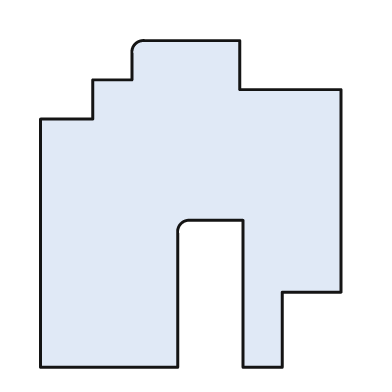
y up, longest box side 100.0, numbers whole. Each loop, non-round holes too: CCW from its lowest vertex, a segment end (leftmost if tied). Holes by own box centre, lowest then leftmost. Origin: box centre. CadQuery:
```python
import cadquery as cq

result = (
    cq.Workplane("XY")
    .moveTo(-46.0, -50.0)
    .lineTo(-4.0, -50.0)
    .lineTo(-4.0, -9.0)
    .threePointArc((-3.0, -6.0), (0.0, -5.0))
    .lineTo(16.0, -5.0)
    .lineTo(16.0, -50.0)
    .lineTo(28.0, -50.0)
    .lineTo(28.0, -27.0)
    .lineTo(46.0, -27.0)
    .lineTo(46.0, 35.0)
    .lineTo(15.0, 35.0)
    .lineTo(15.0, 50.0)
    .lineTo(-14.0, 50.0)
    .threePointArc((-17.0, 49.0), (-18.0, 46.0))
    .lineTo(-18.0, 38.0)
    .lineTo(-30.0, 38.0)
    .lineTo(-30.0, 26.0)
    .lineTo(-46.0, 26.0)
    .close()
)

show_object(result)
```